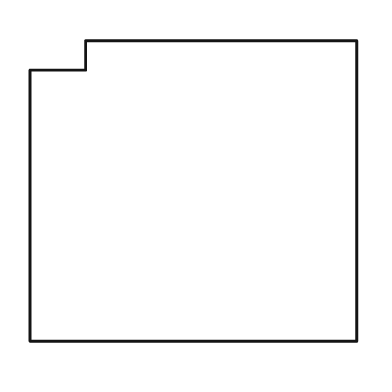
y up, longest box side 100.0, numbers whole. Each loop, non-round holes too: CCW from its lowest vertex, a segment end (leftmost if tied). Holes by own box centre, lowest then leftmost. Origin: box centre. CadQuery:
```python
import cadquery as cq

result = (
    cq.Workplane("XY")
    .moveTo(-50.0, -46.0)
    .lineTo(50.0, -46.0)
    .lineTo(50.0, 46.0)
    .lineTo(-33.0, 46.0)
    .lineTo(-33.0, 37.0)
    .lineTo(-50.0, 37.0)
    .close()
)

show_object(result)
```